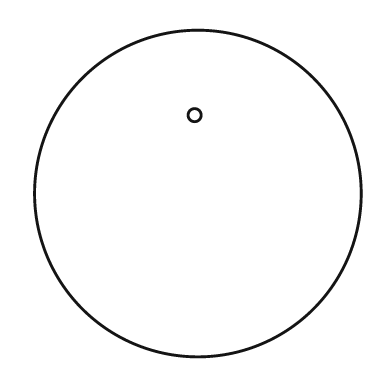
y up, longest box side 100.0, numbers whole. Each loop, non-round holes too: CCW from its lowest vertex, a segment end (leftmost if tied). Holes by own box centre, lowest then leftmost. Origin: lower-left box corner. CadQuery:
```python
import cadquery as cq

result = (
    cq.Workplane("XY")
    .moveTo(50.0, 50.0)
    .circle(50.0)
    .moveTo(49.0, 74.0)
    .circle(2.0)
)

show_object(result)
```